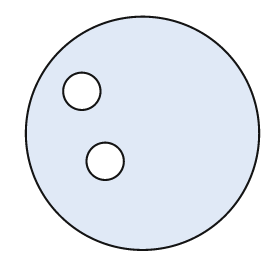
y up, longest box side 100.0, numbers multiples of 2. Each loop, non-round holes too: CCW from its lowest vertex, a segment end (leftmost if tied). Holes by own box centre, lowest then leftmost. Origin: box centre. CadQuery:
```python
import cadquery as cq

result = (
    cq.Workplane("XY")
    .moveTo(0.0, 0.0)
    .circle(50.0)
    .moveTo(-16.0, -12.0)
    .circle(8.0)
    .moveTo(-26.0, 18.0)
    .circle(8.0)
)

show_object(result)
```